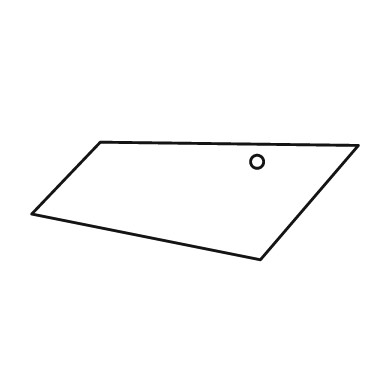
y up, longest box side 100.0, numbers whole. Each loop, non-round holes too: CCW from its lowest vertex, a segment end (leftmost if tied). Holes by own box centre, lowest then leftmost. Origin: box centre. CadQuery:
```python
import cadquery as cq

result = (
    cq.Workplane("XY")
    .moveTo(20.0, -18.0)
    .lineTo(50.0, 17.0)
    .lineTo(-29.0, 18.0)
    .lineTo(-50.0, -4.0)
    .close()
    .moveTo(19.0, 12.0)
    .circle(2.0)
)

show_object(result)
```